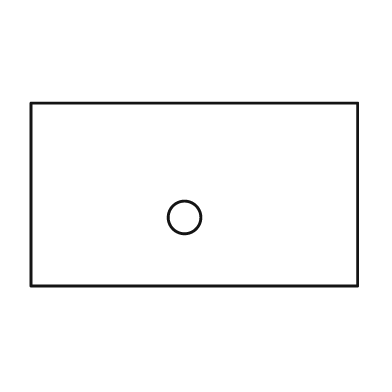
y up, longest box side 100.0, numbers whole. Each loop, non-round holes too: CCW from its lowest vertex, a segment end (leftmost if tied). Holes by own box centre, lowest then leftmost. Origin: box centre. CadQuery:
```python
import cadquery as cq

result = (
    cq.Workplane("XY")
    .moveTo(-50.0, -28.0)
    .lineTo(50.0, -28.0)
    .lineTo(50.0, 28.0)
    .lineTo(-50.0, 28.0)
    .close()
    .moveTo(-3.0, -7.0)
    .circle(5.0)
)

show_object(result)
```